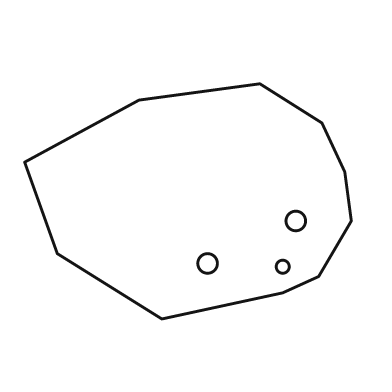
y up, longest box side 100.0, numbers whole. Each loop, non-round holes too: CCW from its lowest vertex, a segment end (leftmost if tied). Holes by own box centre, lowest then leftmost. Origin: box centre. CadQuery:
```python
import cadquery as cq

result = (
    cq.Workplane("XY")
    .moveTo(-8.0, -36.0)
    .lineTo(29.0, -28.0)
    .lineTo(40.0, -23.0)
    .lineTo(50.0, -6.0)
    .lineTo(48.0, 9.0)
    .lineTo(41.0, 24.0)
    .lineTo(22.0, 36.0)
    .lineTo(-15.0, 31.0)
    .lineTo(-50.0, 12.0)
    .lineTo(-40.0, -16.0)
    .close()
    .moveTo(29.0, -20.0)
    .circle(2.0)
    .moveTo(6.0, -19.0)
    .circle(3.0)
    .moveTo(33.0, -6.0)
    .circle(3.0)
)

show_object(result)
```